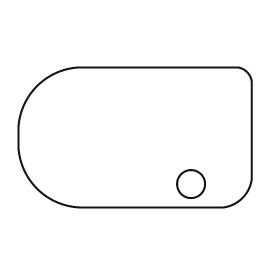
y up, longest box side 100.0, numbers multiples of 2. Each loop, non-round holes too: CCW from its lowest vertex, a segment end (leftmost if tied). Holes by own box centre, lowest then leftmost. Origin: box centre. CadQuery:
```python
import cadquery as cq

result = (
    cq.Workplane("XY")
    .moveTo(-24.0, -30.0)
    .lineTo(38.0, -30.0)
    .threePointArc((46.0, -26.0), (50.0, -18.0))
    .lineTo(50.0, 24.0)
    .threePointArc((48.0, 28.0), (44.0, 30.0))
    .lineTo(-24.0, 30.0)
    .threePointArc((-42.0, 22.0), (-50.0, 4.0))
    .lineTo(-50.0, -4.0)
    .threePointArc((-42.0, -22.0), (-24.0, -30.0))
    .close()
    .moveTo(24.0, -20.0)
    .circle(6.0)
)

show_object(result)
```